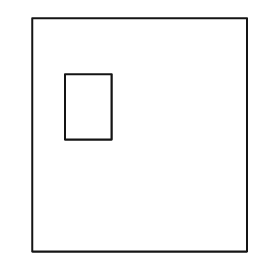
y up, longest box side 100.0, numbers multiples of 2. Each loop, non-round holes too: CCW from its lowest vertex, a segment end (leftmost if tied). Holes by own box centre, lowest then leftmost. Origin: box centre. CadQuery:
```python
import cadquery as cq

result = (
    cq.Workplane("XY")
    .moveTo(-46.0, -50.0)
    .lineTo(46.0, -50.0)
    .lineTo(46.0, 50.0)
    .lineTo(-46.0, 50.0)
    .close()
    .moveTo(-32.0, -2.0)
    .lineTo(-12.0, -2.0)
    .lineTo(-12.0, 26.0)
    .lineTo(-32.0, 26.0)
    .close()
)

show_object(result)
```